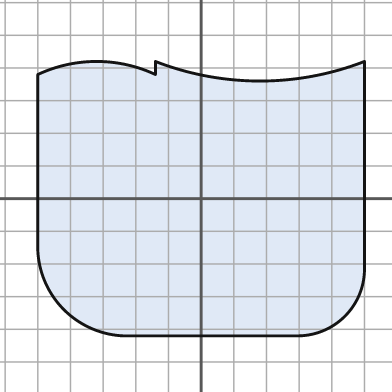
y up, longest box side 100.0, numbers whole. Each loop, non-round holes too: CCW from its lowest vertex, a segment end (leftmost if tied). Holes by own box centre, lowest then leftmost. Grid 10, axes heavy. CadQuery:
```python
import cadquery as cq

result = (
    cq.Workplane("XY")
    .moveTo(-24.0, -42.0)
    .lineTo(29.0, -42.0)
    .threePointArc((44.0, -36.0), (50.0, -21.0))
    .lineTo(50.0, 42.0)
    .threePointArc((18.0, 36.0), (-14.0, 42.0))
    .lineTo(-14.0, 38.0)
    .threePointArc((-32.0, 42.0), (-50.0, 38.0))
    .lineTo(-50.0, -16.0)
    .threePointArc((-42.0, -34.0), (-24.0, -42.0))
    .close()
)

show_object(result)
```